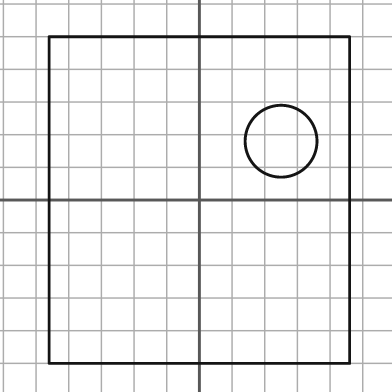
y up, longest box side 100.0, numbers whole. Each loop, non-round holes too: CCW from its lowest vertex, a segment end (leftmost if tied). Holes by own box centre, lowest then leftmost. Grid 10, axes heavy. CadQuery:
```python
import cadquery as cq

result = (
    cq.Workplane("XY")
    .moveTo(-46.0, -50.0)
    .lineTo(46.0, -50.0)
    .lineTo(46.0, 50.0)
    .lineTo(-46.0, 50.0)
    .close()
    .moveTo(25.0, 18.0)
    .circle(11.0)
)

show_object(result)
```